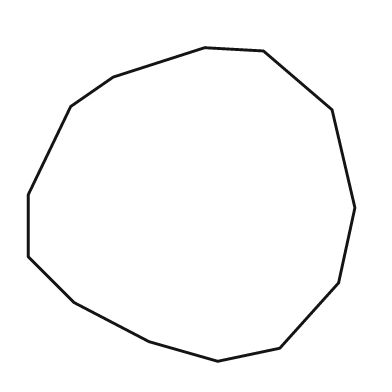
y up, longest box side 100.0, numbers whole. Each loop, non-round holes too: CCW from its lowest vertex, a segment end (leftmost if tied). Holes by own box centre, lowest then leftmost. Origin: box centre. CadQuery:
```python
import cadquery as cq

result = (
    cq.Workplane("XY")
    .moveTo(8.0, -48.0)
    .lineTo(27.0, -44.0)
    .lineTo(45.0, -24.0)
    .lineTo(50.0, -1.0)
    .lineTo(43.0, 29.0)
    .lineTo(22.0, 47.0)
    .lineTo(4.0, 48.0)
    .lineTo(-24.0, 39.0)
    .lineTo(-37.0, 30.0)
    .lineTo(-50.0, 3.0)
    .lineTo(-50.0, -16.0)
    .lineTo(-36.0, -30.0)
    .lineTo(-13.0, -42.0)
    .close()
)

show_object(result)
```